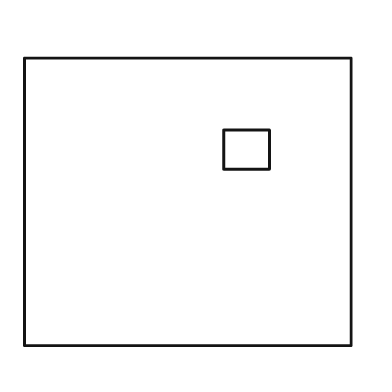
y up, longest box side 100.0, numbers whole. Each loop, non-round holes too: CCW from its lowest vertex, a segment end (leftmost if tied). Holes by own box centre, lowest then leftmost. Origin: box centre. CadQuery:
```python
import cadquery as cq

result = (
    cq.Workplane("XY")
    .moveTo(-50.0, -44.0)
    .lineTo(50.0, -44.0)
    .lineTo(50.0, 44.0)
    .lineTo(-50.0, 44.0)
    .close()
    .moveTo(11.0, 10.0)
    .lineTo(25.0, 10.0)
    .lineTo(25.0, 22.0)
    .lineTo(11.0, 22.0)
    .close()
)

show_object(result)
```